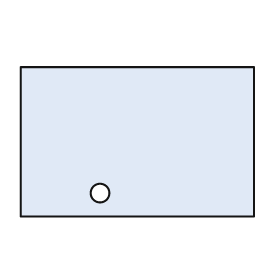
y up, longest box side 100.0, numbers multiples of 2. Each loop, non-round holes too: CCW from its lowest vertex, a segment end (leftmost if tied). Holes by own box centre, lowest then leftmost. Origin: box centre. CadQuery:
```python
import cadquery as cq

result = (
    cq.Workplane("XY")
    .moveTo(-50.0, -32.0)
    .lineTo(50.0, -32.0)
    .lineTo(50.0, 32.0)
    .lineTo(-50.0, 32.0)
    .close()
    .moveTo(-16.0, -22.0)
    .circle(4.0)
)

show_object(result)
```